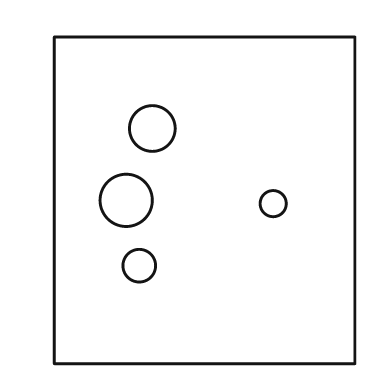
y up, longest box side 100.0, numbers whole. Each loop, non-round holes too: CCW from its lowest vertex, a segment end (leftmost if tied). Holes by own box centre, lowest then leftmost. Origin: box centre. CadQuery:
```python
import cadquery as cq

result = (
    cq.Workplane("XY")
    .moveTo(-46.0, -50.0)
    .lineTo(46.0, -50.0)
    .lineTo(46.0, 50.0)
    .lineTo(-46.0, 50.0)
    .close()
    .moveTo(-20.0, -20.0)
    .circle(5.0)
    .moveTo(21.0, -1.0)
    .circle(4.0)
    .moveTo(-24.0, 0.0)
    .circle(8.0)
    .moveTo(-16.0, 22.0)
    .circle(7.0)
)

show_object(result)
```